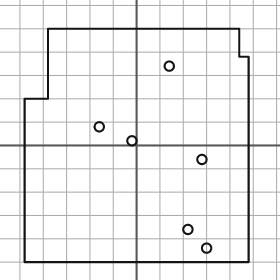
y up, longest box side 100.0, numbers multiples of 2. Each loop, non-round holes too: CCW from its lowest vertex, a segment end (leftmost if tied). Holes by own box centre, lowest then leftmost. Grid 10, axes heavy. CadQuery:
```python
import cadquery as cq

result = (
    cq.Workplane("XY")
    .moveTo(-48.0, -50.0)
    .lineTo(48.0, -50.0)
    .lineTo(48.0, 38.0)
    .lineTo(44.0, 38.0)
    .lineTo(44.0, 50.0)
    .lineTo(-38.0, 50.0)
    .lineTo(-38.0, 20.0)
    .lineTo(-48.0, 20.0)
    .close()
    .moveTo(30.0, -44.0)
    .circle(2.0)
    .moveTo(22.0, -36.0)
    .circle(2.0)
    .moveTo(28.0, -6.0)
    .circle(2.0)
    .moveTo(-2.0, 2.0)
    .circle(2.0)
    .moveTo(-16.0, 8.0)
    .circle(2.0)
    .moveTo(14.0, 34.0)
    .circle(2.0)
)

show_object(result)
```